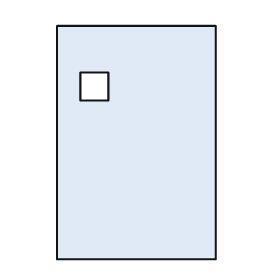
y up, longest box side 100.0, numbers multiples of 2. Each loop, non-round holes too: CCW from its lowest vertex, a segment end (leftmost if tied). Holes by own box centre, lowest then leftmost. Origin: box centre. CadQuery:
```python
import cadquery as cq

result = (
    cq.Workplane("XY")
    .moveTo(-34.0, -50.0)
    .lineTo(34.0, -50.0)
    .lineTo(34.0, 50.0)
    .lineTo(-34.0, 50.0)
    .close()
    .moveTo(-24.0, 18.0)
    .lineTo(-12.0, 18.0)
    .lineTo(-12.0, 30.0)
    .lineTo(-24.0, 30.0)
    .close()
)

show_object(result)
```